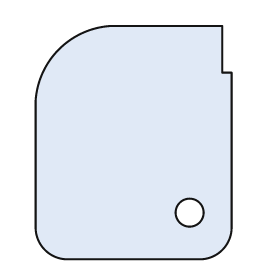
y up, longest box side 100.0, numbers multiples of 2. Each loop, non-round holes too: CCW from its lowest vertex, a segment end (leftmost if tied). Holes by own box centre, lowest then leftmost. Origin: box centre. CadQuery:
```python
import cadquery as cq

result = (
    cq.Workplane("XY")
    .moveTo(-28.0, -50.0)
    .lineTo(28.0, -50.0)
    .threePointArc((38.0, -46.0), (42.0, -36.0))
    .lineTo(42.0, 30.0)
    .lineTo(38.0, 30.0)
    .lineTo(38.0, 50.0)
    .lineTo(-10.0, 50.0)
    .threePointArc((-32.0, 40.0), (-42.0, 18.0))
    .lineTo(-42.0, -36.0)
    .threePointArc((-38.0, -46.0), (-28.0, -50.0))
    .close()
    .moveTo(24.0, -30.0)
    .circle(6.0)
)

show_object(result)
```